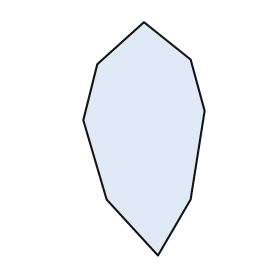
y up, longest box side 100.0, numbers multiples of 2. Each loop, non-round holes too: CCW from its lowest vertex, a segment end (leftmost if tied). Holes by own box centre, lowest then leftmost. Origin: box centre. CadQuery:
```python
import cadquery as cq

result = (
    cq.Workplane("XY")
    .moveTo(6.0, -50.0)
    .lineTo(20.0, -26.0)
    .lineTo(26.0, 12.0)
    .lineTo(20.0, 34.0)
    .lineTo(0.0, 50.0)
    .lineTo(-20.0, 32.0)
    .lineTo(-26.0, 8.0)
    .lineTo(-16.0, -26.0)
    .close()
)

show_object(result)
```